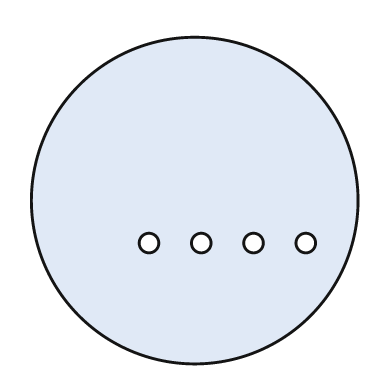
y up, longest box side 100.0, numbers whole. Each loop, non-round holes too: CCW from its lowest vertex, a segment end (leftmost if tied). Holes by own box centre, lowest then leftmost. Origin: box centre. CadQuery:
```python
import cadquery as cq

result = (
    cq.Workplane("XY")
    .moveTo(0.0, 0.0)
    .circle(50.0)
    .moveTo(-14.0, -13.0)
    .circle(3.0)
    .moveTo(2.0, -13.0)
    .circle(3.0)
    .moveTo(18.0, -13.0)
    .circle(3.0)
    .moveTo(34.0, -13.0)
    .circle(3.0)
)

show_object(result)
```